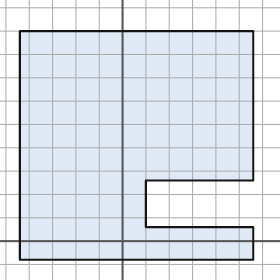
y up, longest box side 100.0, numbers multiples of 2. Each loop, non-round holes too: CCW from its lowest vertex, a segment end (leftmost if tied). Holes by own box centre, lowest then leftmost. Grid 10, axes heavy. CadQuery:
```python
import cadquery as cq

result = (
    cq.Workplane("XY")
    .moveTo(-44.0, -8.0)
    .lineTo(56.0, -8.0)
    .lineTo(56.0, 6.0)
    .lineTo(10.0, 6.0)
    .lineTo(10.0, 26.0)
    .lineTo(56.0, 26.0)
    .lineTo(56.0, 90.0)
    .lineTo(-44.0, 90.0)
    .close()
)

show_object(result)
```